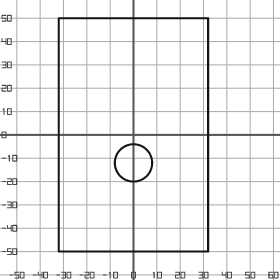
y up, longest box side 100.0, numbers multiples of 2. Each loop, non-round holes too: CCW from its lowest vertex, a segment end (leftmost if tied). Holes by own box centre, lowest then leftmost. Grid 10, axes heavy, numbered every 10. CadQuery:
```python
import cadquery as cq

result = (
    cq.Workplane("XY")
    .moveTo(-32.0, -50.0)
    .lineTo(32.0, -50.0)
    .lineTo(32.0, 50.0)
    .lineTo(-32.0, 50.0)
    .close()
    .moveTo(0.0, -12.0)
    .circle(8.0)
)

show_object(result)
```